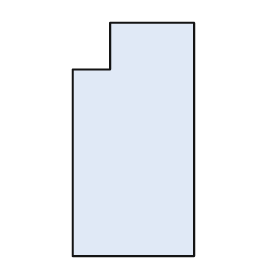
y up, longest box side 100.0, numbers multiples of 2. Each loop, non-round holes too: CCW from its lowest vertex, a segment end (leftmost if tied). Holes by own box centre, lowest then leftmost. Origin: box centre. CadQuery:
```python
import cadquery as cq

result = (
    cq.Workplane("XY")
    .moveTo(-26.0, -50.0)
    .lineTo(26.0, -50.0)
    .lineTo(26.0, 50.0)
    .lineTo(-10.0, 50.0)
    .lineTo(-10.0, 30.0)
    .lineTo(-26.0, 30.0)
    .close()
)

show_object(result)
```